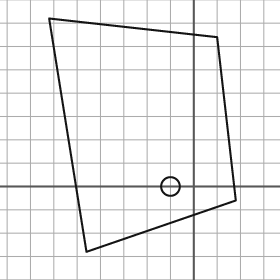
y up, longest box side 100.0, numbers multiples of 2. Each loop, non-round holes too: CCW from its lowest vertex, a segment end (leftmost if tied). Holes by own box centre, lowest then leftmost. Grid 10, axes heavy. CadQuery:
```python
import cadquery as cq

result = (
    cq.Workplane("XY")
    .moveTo(-46.0, -28.0)
    .lineTo(18.0, -6.0)
    .lineTo(10.0, 64.0)
    .lineTo(-62.0, 72.0)
    .close()
    .moveTo(-10.0, 0.0)
    .circle(4.0)
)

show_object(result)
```